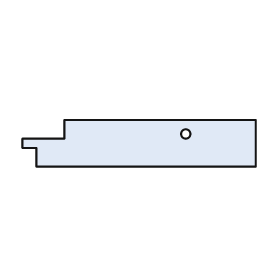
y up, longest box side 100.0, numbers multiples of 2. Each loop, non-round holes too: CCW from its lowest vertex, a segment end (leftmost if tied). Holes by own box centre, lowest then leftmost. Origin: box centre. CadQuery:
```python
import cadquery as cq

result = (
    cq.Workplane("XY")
    .moveTo(-44.0, -10.0)
    .lineTo(50.0, -10.0)
    .lineTo(50.0, 10.0)
    .lineTo(-32.0, 10.0)
    .lineTo(-32.0, 2.0)
    .lineTo(-50.0, 2.0)
    .lineTo(-50.0, -2.0)
    .lineTo(-44.0, -2.0)
    .close()
    .moveTo(20.0, 4.0)
    .circle(2.0)
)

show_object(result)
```